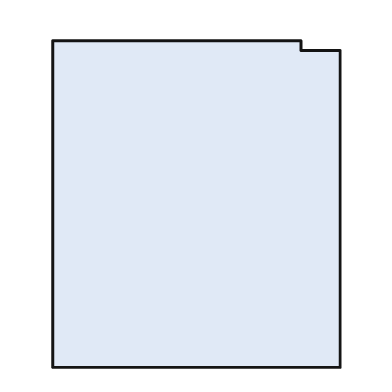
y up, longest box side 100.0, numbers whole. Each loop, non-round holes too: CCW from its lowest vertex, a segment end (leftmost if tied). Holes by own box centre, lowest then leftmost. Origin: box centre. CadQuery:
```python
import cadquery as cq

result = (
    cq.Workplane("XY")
    .moveTo(-44.0, -50.0)
    .lineTo(44.0, -50.0)
    .lineTo(44.0, 47.0)
    .lineTo(32.0, 47.0)
    .lineTo(32.0, 50.0)
    .lineTo(-44.0, 50.0)
    .close()
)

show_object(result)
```